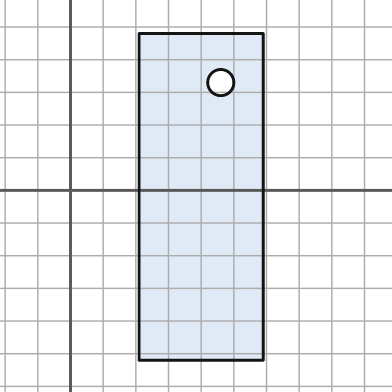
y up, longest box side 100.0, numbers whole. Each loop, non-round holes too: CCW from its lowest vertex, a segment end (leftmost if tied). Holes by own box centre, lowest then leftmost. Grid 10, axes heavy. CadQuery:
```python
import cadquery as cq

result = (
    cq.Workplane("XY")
    .moveTo(21.0, -52.0)
    .lineTo(59.0, -52.0)
    .lineTo(59.0, 48.0)
    .lineTo(21.0, 48.0)
    .close()
    .moveTo(46.0, 33.0)
    .circle(4.0)
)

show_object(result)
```